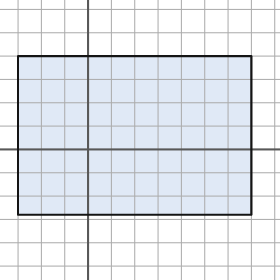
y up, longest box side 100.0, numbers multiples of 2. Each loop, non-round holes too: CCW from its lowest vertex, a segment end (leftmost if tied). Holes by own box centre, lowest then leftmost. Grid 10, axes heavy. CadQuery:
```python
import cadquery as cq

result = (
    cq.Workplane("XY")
    .moveTo(-30.0, -28.0)
    .lineTo(70.0, -28.0)
    .lineTo(70.0, 40.0)
    .lineTo(-30.0, 40.0)
    .close()
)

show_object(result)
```